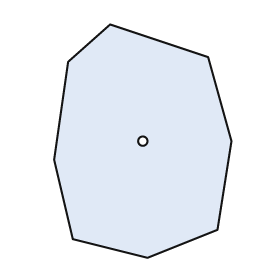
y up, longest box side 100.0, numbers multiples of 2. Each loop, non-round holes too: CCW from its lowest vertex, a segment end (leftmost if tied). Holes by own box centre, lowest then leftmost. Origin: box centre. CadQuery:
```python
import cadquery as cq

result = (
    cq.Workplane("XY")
    .moveTo(2.0, -50.0)
    .lineTo(32.0, -38.0)
    .lineTo(38.0, 0.0)
    .lineTo(28.0, 36.0)
    .lineTo(-14.0, 50.0)
    .lineTo(-32.0, 34.0)
    .lineTo(-38.0, -8.0)
    .lineTo(-30.0, -42.0)
    .close()
    .moveTo(0.0, 0.0)
    .circle(2.0)
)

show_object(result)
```